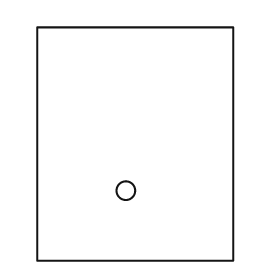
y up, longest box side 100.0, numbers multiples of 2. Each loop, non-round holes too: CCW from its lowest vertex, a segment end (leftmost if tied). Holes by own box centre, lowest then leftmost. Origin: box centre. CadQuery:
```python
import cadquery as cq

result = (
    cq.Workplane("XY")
    .moveTo(-42.0, -50.0)
    .lineTo(42.0, -50.0)
    .lineTo(42.0, 50.0)
    .lineTo(-42.0, 50.0)
    .close()
    .moveTo(-4.0, -20.0)
    .circle(4.0)
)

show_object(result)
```